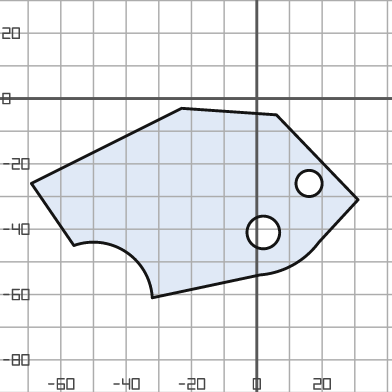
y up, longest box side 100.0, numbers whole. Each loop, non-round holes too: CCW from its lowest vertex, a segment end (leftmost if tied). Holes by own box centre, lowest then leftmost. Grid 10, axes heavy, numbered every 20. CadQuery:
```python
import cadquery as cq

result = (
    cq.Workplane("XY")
    .moveTo(-32.0, -61.0)
    .lineTo(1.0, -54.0)
    .threePointArc((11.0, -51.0), (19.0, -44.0))
    .lineTo(31.0, -31.0)
    .lineTo(6.0, -5.0)
    .lineTo(-23.0, -3.0)
    .lineTo(-69.0, -26.0)
    .lineTo(-56.0, -45.0)
    .threePointArc((-40.0, -47.0), (-32.0, -61.0))
    .close()
    .moveTo(2.0, -41.0)
    .circle(5.0)
    .moveTo(16.0, -26.0)
    .circle(4.0)
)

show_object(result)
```